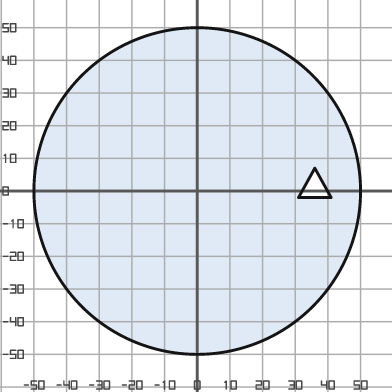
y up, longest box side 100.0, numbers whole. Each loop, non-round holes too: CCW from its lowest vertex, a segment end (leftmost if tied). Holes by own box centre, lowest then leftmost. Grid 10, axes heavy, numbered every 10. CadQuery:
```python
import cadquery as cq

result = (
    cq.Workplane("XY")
    .moveTo(0.0, 0.0)
    .circle(50.0)
    .moveTo(31.0, -2.0)
    .lineTo(41.0, -2.0)
    .lineTo(36.0, 7.0)
    .close()
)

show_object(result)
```